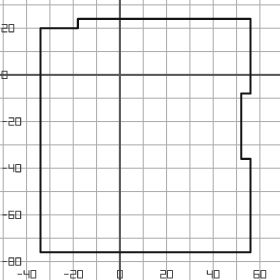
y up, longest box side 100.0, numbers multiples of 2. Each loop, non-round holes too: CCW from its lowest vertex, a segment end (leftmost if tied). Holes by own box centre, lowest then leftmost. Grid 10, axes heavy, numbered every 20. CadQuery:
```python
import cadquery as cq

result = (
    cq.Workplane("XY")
    .moveTo(-34.0, -76.0)
    .lineTo(56.0, -76.0)
    .lineTo(56.0, -36.0)
    .lineTo(52.0, -36.0)
    .lineTo(52.0, -8.0)
    .lineTo(56.0, -8.0)
    .lineTo(56.0, 24.0)
    .lineTo(-18.0, 24.0)
    .lineTo(-18.0, 20.0)
    .lineTo(-34.0, 20.0)
    .close()
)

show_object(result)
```